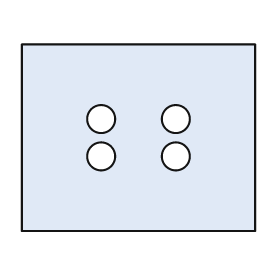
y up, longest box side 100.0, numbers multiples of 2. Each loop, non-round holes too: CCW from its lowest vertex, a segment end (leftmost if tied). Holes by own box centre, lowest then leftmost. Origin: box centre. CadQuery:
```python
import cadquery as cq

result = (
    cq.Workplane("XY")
    .moveTo(-50.0, -40.0)
    .lineTo(50.0, -40.0)
    .lineTo(50.0, 40.0)
    .lineTo(-50.0, 40.0)
    .close()
    .moveTo(-16.0, -8.0)
    .circle(6.0)
    .moveTo(16.0, -8.0)
    .circle(6.0)
    .moveTo(-16.0, 8.0)
    .circle(6.0)
    .moveTo(16.0, 8.0)
    .circle(6.0)
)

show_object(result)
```